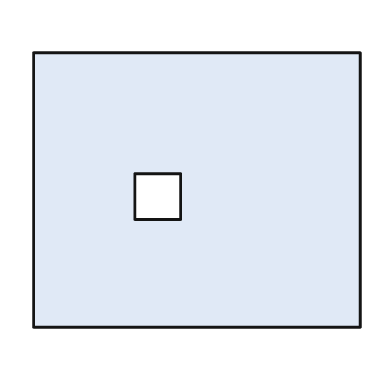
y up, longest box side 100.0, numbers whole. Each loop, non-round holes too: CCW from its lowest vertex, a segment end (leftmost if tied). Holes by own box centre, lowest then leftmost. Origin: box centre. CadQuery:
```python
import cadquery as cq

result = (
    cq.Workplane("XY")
    .moveTo(-50.0, -42.0)
    .lineTo(50.0, -42.0)
    .lineTo(50.0, 42.0)
    .lineTo(-50.0, 42.0)
    .close()
    .moveTo(-19.0, -9.0)
    .lineTo(-5.0, -9.0)
    .lineTo(-5.0, 5.0)
    .lineTo(-19.0, 5.0)
    .close()
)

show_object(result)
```